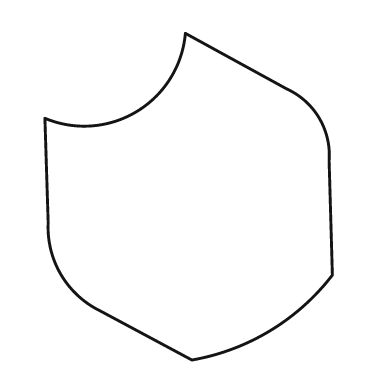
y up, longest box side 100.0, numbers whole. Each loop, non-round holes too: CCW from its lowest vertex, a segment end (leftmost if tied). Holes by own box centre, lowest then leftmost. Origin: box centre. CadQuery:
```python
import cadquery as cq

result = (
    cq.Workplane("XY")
    .moveTo(1.0, -50.0)
    .threePointArc((25.0, -41.0), (44.0, -24.0))
    .lineTo(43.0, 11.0)
    .threePointArc((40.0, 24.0), (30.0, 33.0))
    .lineTo(-1.0, 50.0)
    .threePointArc((-16.0, 26.0), (-44.0, 24.0))
    .lineTo(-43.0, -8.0)
    .threePointArc((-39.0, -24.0), (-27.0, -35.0))
    .close()
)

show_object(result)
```